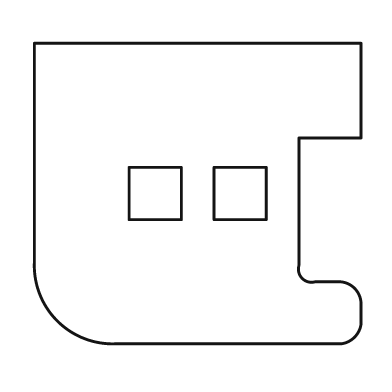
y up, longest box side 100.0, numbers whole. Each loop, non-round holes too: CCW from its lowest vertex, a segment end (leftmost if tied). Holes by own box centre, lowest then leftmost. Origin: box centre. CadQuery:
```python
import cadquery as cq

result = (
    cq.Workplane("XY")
    .moveTo(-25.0, -46.0)
    .lineTo(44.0, -46.0)
    .threePointArc((48.0, -44.0), (50.0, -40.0))
    .lineTo(50.0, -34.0)
    .threePointArc((48.0, -29.0), (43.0, -27.0))
    .lineTo(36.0, -27.0)
    .threePointArc((32.0, -26.0), (31.0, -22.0))
    .lineTo(31.0, 17.0)
    .lineTo(50.0, 17.0)
    .lineTo(50.0, 46.0)
    .lineTo(-50.0, 46.0)
    .lineTo(-50.0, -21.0)
    .threePointArc((-43.0, -39.0), (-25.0, -46.0))
    .close()
    .moveTo(-21.0, -8.0)
    .lineTo(-5.0, -8.0)
    .lineTo(-5.0, 8.0)
    .lineTo(-21.0, 8.0)
    .close()
    .moveTo(5.0, -8.0)
    .lineTo(21.0, -8.0)
    .lineTo(21.0, 8.0)
    .lineTo(5.0, 8.0)
    .close()
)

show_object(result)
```